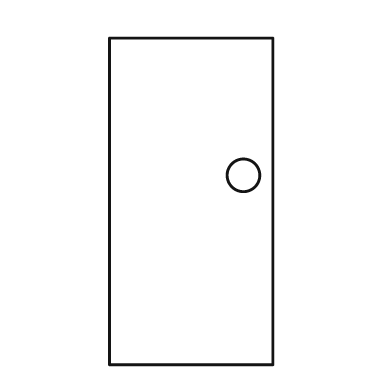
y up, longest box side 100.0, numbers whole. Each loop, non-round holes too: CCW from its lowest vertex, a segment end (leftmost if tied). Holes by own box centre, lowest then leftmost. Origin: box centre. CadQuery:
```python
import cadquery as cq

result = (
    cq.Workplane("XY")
    .moveTo(-25.0, -50.0)
    .lineTo(25.0, -50.0)
    .lineTo(25.0, 50.0)
    .lineTo(-25.0, 50.0)
    .close()
    .moveTo(16.0, 8.0)
    .circle(5.0)
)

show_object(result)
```